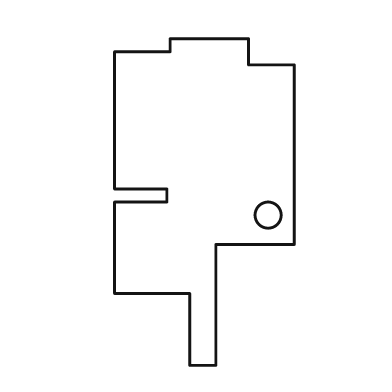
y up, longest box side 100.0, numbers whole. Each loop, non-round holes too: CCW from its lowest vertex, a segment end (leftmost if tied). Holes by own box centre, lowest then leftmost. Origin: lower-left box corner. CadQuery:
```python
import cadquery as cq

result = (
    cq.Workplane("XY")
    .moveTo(23.0, 0.0)
    .lineTo(31.0, 0.0)
    .lineTo(31.0, 37.0)
    .lineTo(55.0, 37.0)
    .lineTo(55.0, 92.0)
    .lineTo(41.0, 92.0)
    .lineTo(41.0, 100.0)
    .lineTo(17.0, 100.0)
    .lineTo(17.0, 96.0)
    .lineTo(0.0, 96.0)
    .lineTo(0.0, 54.0)
    .lineTo(16.0, 54.0)
    .lineTo(16.0, 50.0)
    .lineTo(0.0, 50.0)
    .lineTo(0.0, 22.0)
    .lineTo(23.0, 22.0)
    .close()
    .moveTo(47.0, 46.0)
    .circle(4.0)
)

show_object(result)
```